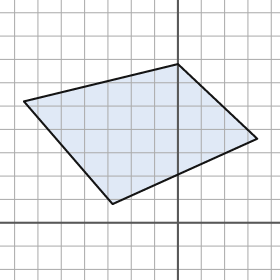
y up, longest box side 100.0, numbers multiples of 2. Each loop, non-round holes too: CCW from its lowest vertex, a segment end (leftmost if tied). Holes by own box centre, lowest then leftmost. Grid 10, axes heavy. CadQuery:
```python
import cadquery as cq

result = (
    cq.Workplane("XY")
    .moveTo(-28.0, 8.0)
    .lineTo(34.0, 36.0)
    .lineTo(0.0, 68.0)
    .lineTo(-66.0, 52.0)
    .close()
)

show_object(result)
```